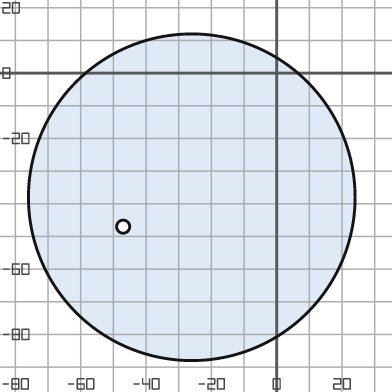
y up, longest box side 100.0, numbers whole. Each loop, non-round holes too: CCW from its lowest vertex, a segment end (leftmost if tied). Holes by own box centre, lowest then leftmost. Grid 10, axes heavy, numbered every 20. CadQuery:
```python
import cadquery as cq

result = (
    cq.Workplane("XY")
    .moveTo(-26.0, -38.0)
    .circle(50.0)
    .moveTo(-47.0, -47.0)
    .circle(2.0)
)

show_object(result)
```